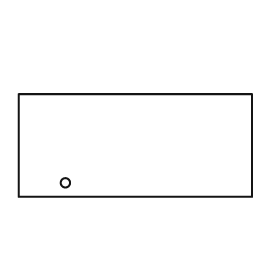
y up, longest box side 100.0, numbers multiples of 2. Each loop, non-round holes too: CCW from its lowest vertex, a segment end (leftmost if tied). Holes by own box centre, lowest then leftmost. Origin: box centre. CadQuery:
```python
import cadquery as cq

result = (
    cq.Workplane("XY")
    .moveTo(-50.0, -22.0)
    .lineTo(50.0, -22.0)
    .lineTo(50.0, 22.0)
    .lineTo(-50.0, 22.0)
    .close()
    .moveTo(-30.0, -16.0)
    .circle(2.0)
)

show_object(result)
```